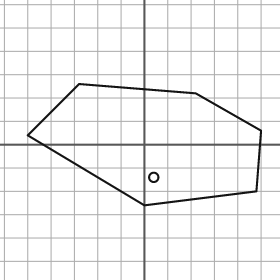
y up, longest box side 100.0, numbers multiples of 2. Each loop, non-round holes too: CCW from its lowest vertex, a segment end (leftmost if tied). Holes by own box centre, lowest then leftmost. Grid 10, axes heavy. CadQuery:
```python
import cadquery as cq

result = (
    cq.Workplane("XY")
    .moveTo(0.0, -26.0)
    .lineTo(48.0, -20.0)
    .lineTo(50.0, 6.0)
    .lineTo(22.0, 22.0)
    .lineTo(-28.0, 26.0)
    .lineTo(-50.0, 4.0)
    .close()
    .moveTo(4.0, -14.0)
    .circle(2.0)
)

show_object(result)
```